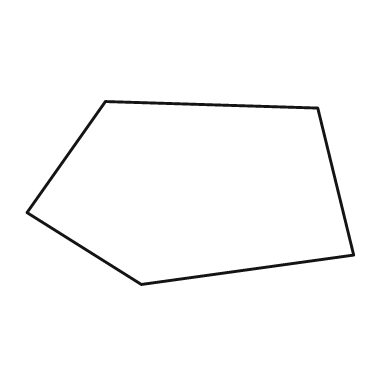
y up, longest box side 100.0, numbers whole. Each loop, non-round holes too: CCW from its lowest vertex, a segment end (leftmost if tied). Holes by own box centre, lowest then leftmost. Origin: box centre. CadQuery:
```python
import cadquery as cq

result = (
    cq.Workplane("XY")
    .moveTo(-15.0, -28.0)
    .lineTo(50.0, -19.0)
    .lineTo(39.0, 26.0)
    .lineTo(-26.0, 28.0)
    .lineTo(-50.0, -6.0)
    .close()
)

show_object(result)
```